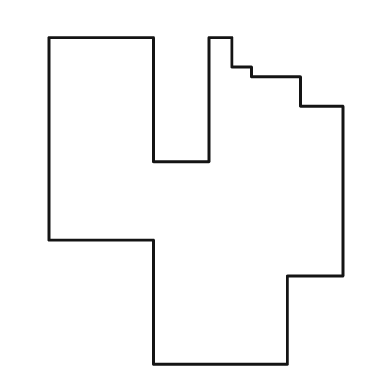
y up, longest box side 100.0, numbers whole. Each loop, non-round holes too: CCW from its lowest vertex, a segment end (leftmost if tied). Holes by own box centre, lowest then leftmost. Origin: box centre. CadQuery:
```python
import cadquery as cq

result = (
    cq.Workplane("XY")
    .moveTo(-13.0, -50.0)
    .lineTo(28.0, -50.0)
    .lineTo(28.0, -23.0)
    .lineTo(45.0, -23.0)
    .lineTo(45.0, 29.0)
    .lineTo(32.0, 29.0)
    .lineTo(32.0, 38.0)
    .lineTo(17.0, 38.0)
    .lineTo(17.0, 41.0)
    .lineTo(11.0, 41.0)
    .lineTo(11.0, 50.0)
    .lineTo(4.0, 50.0)
    .lineTo(4.0, 12.0)
    .lineTo(-13.0, 12.0)
    .lineTo(-13.0, 50.0)
    .lineTo(-45.0, 50.0)
    .lineTo(-45.0, -12.0)
    .lineTo(-13.0, -12.0)
    .close()
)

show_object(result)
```